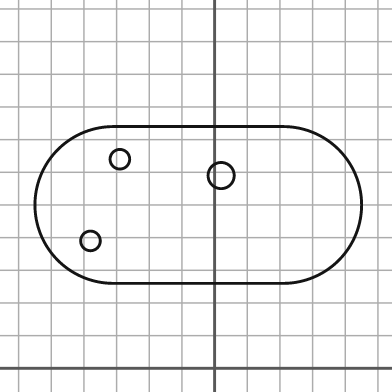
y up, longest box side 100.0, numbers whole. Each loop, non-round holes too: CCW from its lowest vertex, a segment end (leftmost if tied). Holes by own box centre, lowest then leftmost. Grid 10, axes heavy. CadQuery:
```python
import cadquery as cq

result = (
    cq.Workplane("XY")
    .moveTo(-31.0, 26.0)
    .lineTo(21.0, 26.0)
    .threePointArc((45.0, 50.0), (21.0, 74.0))
    .lineTo(-31.0, 74.0)
    .threePointArc((-55.0, 50.0), (-31.0, 26.0))
    .close()
    .moveTo(-38.0, 39.0)
    .circle(3.0)
    .moveTo(2.0, 59.0)
    .circle(4.0)
    .moveTo(-29.0, 64.0)
    .circle(3.0)
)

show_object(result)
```